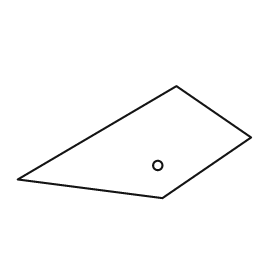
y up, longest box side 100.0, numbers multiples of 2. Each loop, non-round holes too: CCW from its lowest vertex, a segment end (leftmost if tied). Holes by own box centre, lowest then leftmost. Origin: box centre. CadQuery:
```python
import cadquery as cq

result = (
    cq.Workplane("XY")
    .moveTo(12.0, -24.0)
    .lineTo(50.0, 2.0)
    .lineTo(18.0, 24.0)
    .lineTo(-50.0, -16.0)
    .close()
    .moveTo(10.0, -10.0)
    .circle(2.0)
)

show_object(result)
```